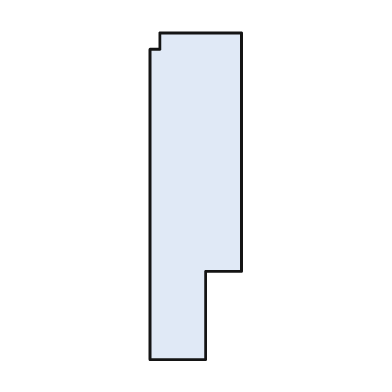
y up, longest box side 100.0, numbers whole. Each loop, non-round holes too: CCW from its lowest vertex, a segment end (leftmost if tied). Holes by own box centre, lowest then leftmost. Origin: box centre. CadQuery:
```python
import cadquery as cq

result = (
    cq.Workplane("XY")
    .moveTo(-14.0, -50.0)
    .lineTo(3.0, -50.0)
    .lineTo(3.0, -23.0)
    .lineTo(14.0, -23.0)
    .lineTo(14.0, 50.0)
    .lineTo(-11.0, 50.0)
    .lineTo(-11.0, 45.0)
    .lineTo(-14.0, 45.0)
    .close()
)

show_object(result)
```